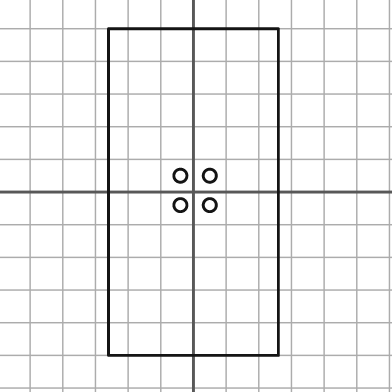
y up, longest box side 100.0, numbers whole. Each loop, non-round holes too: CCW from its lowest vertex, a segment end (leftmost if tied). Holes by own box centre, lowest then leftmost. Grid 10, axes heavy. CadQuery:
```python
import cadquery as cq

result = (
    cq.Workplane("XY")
    .moveTo(-26.0, -50.0)
    .lineTo(26.0, -50.0)
    .lineTo(26.0, 50.0)
    .lineTo(-26.0, 50.0)
    .close()
    .moveTo(-4.0, -4.0)
    .circle(2.0)
    .moveTo(5.0, -4.0)
    .circle(2.0)
    .moveTo(-4.0, 5.0)
    .circle(2.0)
    .moveTo(5.0, 5.0)
    .circle(2.0)
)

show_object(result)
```